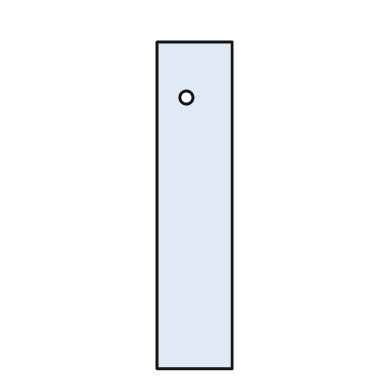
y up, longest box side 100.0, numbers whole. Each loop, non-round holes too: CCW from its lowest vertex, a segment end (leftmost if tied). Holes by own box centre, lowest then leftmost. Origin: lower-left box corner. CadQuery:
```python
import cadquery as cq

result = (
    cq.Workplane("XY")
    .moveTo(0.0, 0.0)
    .lineTo(23.0, 0.0)
    .lineTo(23.0, 100.0)
    .lineTo(0.0, 100.0)
    .close()
    .moveTo(9.0, 83.0)
    .circle(2.0)
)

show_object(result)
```